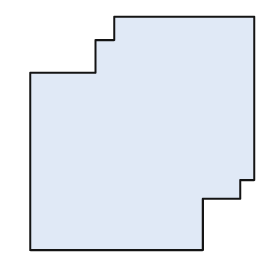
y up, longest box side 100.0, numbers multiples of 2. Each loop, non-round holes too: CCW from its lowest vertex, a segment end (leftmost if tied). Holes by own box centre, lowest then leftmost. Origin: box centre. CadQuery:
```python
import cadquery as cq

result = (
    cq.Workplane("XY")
    .moveTo(-48.0, -50.0)
    .lineTo(26.0, -50.0)
    .lineTo(26.0, -28.0)
    .lineTo(42.0, -28.0)
    .lineTo(42.0, -20.0)
    .lineTo(48.0, -20.0)
    .lineTo(48.0, 50.0)
    .lineTo(-12.0, 50.0)
    .lineTo(-12.0, 40.0)
    .lineTo(-20.0, 40.0)
    .lineTo(-20.0, 26.0)
    .lineTo(-48.0, 26.0)
    .close()
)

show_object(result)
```